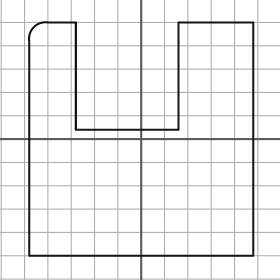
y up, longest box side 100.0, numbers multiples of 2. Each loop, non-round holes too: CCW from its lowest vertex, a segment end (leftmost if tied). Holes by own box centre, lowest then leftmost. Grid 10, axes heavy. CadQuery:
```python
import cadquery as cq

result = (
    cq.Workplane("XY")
    .moveTo(-48.0, -50.0)
    .lineTo(48.0, -50.0)
    .lineTo(48.0, 50.0)
    .lineTo(16.0, 50.0)
    .lineTo(16.0, 4.0)
    .lineTo(-28.0, 4.0)
    .lineTo(-28.0, 50.0)
    .lineTo(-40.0, 50.0)
    .threePointArc((-46.0, 48.0), (-48.0, 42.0))
    .close()
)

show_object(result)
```